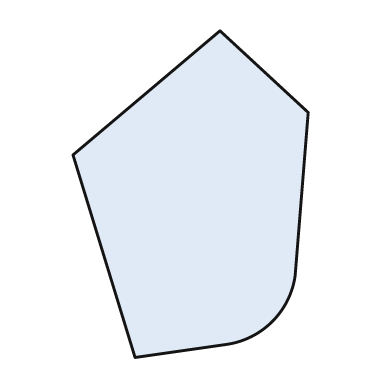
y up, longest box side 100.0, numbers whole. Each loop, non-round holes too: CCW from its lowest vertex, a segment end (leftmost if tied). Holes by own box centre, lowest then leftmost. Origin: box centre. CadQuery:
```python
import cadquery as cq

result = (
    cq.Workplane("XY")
    .moveTo(-17.0, -50.0)
    .lineTo(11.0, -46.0)
    .threePointArc((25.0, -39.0), (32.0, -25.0))
    .lineTo(36.0, 25.0)
    .lineTo(9.0, 50.0)
    .lineTo(-36.0, 12.0)
    .close()
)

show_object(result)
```